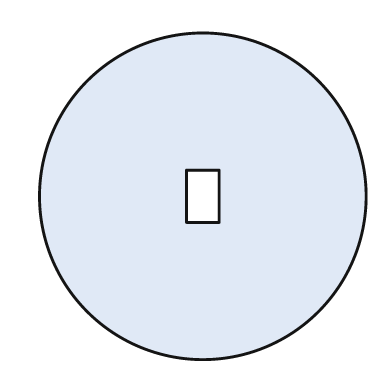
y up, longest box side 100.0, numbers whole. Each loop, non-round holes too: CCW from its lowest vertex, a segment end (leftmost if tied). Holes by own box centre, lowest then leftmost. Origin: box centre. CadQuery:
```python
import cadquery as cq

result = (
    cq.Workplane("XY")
    .moveTo(0.0, 0.0)
    .circle(50.0)
    .moveTo(-5.0, -8.0)
    .lineTo(5.0, -8.0)
    .lineTo(5.0, 8.0)
    .lineTo(-5.0, 8.0)
    .close()
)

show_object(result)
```